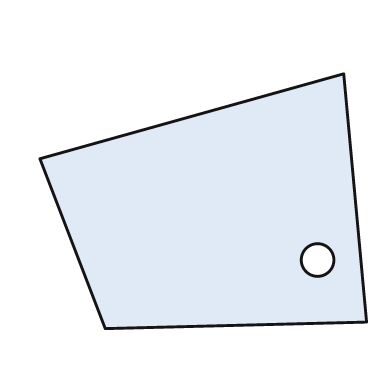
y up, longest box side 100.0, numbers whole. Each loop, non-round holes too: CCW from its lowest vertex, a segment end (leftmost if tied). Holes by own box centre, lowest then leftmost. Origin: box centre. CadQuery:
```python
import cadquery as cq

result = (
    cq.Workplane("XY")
    .moveTo(-30.0, -39.0)
    .lineTo(50.0, -37.0)
    .lineTo(43.0, 39.0)
    .lineTo(-50.0, 13.0)
    .close()
    .moveTo(35.0, -18.0)
    .circle(5.0)
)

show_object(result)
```